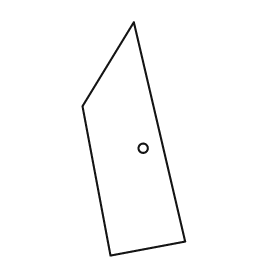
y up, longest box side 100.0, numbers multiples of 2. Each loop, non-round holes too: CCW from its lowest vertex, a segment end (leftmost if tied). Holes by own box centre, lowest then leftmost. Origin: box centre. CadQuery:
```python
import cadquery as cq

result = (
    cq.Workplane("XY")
    .moveTo(-10.0, -50.0)
    .lineTo(22.0, -44.0)
    .lineTo(0.0, 50.0)
    .lineTo(-22.0, 14.0)
    .close()
    .moveTo(4.0, -4.0)
    .circle(2.0)
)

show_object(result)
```